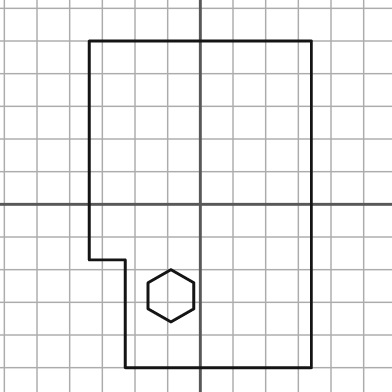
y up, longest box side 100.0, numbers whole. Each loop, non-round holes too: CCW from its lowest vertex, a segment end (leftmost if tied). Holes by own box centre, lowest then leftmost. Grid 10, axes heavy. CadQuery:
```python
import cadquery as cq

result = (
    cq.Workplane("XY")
    .moveTo(-23.0, -50.0)
    .lineTo(34.0, -50.0)
    .lineTo(34.0, 50.0)
    .lineTo(-34.0, 50.0)
    .lineTo(-34.0, -17.0)
    .lineTo(-23.0, -17.0)
    .close()
    .moveTo(-9.0, -36.0)
    .lineTo(-2.0, -32.0)
    .lineTo(-2.0, -24.0)
    .lineTo(-9.0, -20.0)
    .lineTo(-16.0, -24.0)
    .lineTo(-16.0, -32.0)
    .close()
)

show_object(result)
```